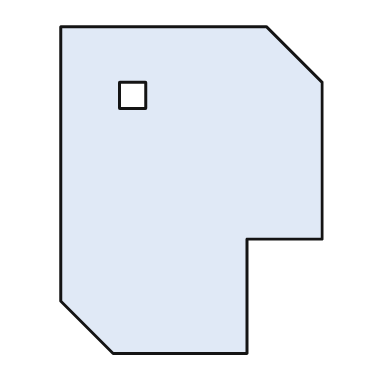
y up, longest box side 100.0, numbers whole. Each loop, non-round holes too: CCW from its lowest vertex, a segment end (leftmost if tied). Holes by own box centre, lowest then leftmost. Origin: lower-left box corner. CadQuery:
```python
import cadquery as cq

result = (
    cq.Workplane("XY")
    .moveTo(16.0, 0.0)
    .lineTo(57.0, 0.0)
    .lineTo(57.0, 35.0)
    .lineTo(80.0, 35.0)
    .lineTo(80.0, 83.0)
    .lineTo(63.0, 100.0)
    .lineTo(0.0, 100.0)
    .lineTo(0.0, 16.0)
    .close()
    .moveTo(18.0, 75.0)
    .lineTo(26.0, 75.0)
    .lineTo(26.0, 83.0)
    .lineTo(18.0, 83.0)
    .close()
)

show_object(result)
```